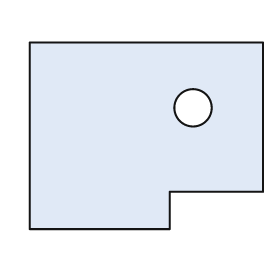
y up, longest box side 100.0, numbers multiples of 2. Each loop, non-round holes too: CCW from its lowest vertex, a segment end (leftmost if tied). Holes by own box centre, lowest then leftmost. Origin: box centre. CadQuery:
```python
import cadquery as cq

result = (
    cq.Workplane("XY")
    .moveTo(-50.0, -40.0)
    .lineTo(10.0, -40.0)
    .lineTo(10.0, -24.0)
    .lineTo(50.0, -24.0)
    .lineTo(50.0, 40.0)
    .lineTo(-50.0, 40.0)
    .close()
    .moveTo(20.0, 12.0)
    .circle(8.0)
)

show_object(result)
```